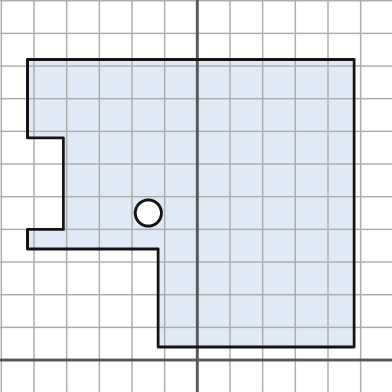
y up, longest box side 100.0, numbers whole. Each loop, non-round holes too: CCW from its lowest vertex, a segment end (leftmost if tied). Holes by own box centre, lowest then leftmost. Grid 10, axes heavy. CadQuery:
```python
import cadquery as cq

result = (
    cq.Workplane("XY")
    .moveTo(-12.0, 4.0)
    .lineTo(48.0, 4.0)
    .lineTo(48.0, 92.0)
    .lineTo(-52.0, 92.0)
    .lineTo(-52.0, 68.0)
    .lineTo(-41.0, 68.0)
    .lineTo(-41.0, 40.0)
    .lineTo(-52.0, 40.0)
    .lineTo(-52.0, 34.0)
    .lineTo(-12.0, 34.0)
    .close()
    .moveTo(-15.0, 45.0)
    .circle(4.0)
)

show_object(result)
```